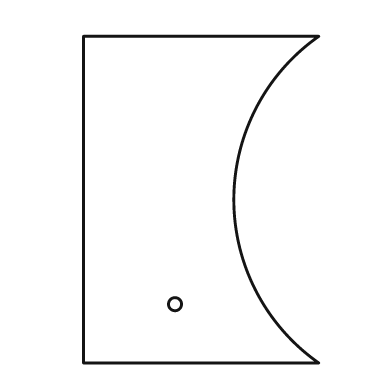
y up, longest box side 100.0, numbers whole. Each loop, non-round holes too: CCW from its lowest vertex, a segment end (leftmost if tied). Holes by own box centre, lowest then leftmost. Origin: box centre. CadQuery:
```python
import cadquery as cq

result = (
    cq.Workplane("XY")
    .moveTo(-36.0, -50.0)
    .lineTo(36.0, -50.0)
    .threePointArc((10.0, 0.0), (36.0, 50.0))
    .lineTo(-36.0, 50.0)
    .close()
    .moveTo(-8.0, -32.0)
    .circle(2.0)
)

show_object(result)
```